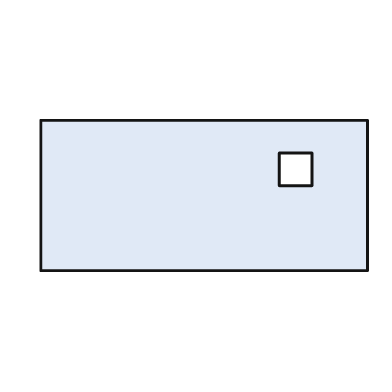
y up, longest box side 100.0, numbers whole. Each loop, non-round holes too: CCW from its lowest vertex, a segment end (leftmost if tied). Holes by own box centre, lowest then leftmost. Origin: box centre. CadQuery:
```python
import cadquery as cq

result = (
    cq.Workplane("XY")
    .moveTo(-50.0, -23.0)
    .lineTo(50.0, -23.0)
    .lineTo(50.0, 23.0)
    .lineTo(-50.0, 23.0)
    .close()
    .moveTo(23.0, 3.0)
    .lineTo(33.0, 3.0)
    .lineTo(33.0, 13.0)
    .lineTo(23.0, 13.0)
    .close()
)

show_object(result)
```